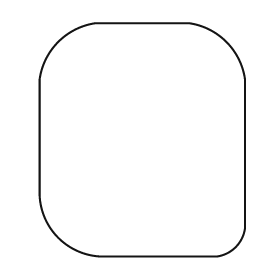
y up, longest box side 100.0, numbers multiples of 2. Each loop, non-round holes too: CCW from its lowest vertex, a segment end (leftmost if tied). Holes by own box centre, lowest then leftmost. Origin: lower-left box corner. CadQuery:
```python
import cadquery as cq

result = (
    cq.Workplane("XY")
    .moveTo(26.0, 0.0)
    .lineTo(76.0, 0.0)
    .threePointArc((84.0, 4.0), (88.0, 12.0))
    .lineTo(88.0, 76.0)
    .threePointArc((80.0, 92.0), (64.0, 100.0))
    .lineTo(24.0, 100.0)
    .threePointArc((8.0, 92.0), (0.0, 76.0))
    .lineTo(0.0, 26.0)
    .threePointArc((8.0, 8.0), (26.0, 0.0))
    .close()
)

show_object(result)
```